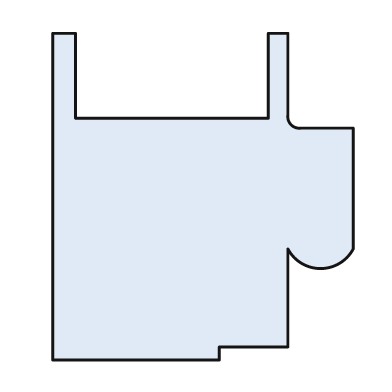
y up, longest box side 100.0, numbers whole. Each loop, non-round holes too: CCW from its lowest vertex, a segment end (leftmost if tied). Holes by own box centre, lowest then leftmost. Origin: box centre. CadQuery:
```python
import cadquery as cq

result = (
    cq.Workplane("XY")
    .moveTo(-46.0, -50.0)
    .lineTo(5.0, -50.0)
    .lineTo(5.0, -46.0)
    .lineTo(26.0, -46.0)
    .lineTo(26.0, -16.0)
    .threePointArc((36.0, -22.0), (46.0, -16.0))
    .lineTo(46.0, 21.0)
    .lineTo(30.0, 21.0)
    .threePointArc((27.0, 22.0), (26.0, 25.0))
    .lineTo(26.0, 50.0)
    .lineTo(20.0, 50.0)
    .lineTo(20.0, 24.0)
    .lineTo(-39.0, 24.0)
    .lineTo(-39.0, 50.0)
    .lineTo(-46.0, 50.0)
    .close()
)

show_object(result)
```